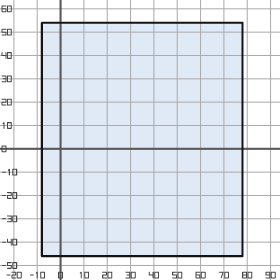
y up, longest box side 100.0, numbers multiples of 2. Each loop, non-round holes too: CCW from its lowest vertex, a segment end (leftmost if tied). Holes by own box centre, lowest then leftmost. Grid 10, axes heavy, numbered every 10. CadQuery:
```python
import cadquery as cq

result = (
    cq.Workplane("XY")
    .moveTo(-8.0, -46.0)
    .lineTo(78.0, -46.0)
    .lineTo(78.0, 54.0)
    .lineTo(-8.0, 54.0)
    .close()
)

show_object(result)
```